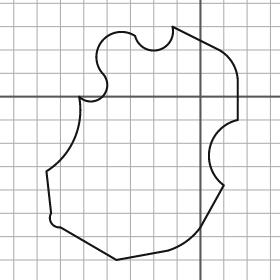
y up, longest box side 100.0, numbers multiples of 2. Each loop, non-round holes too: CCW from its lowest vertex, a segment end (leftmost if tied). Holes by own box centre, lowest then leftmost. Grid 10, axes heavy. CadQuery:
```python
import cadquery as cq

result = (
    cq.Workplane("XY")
    .moveTo(-36.0, -70.0)
    .lineTo(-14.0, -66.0)
    .threePointArc((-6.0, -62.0), (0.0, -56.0))
    .lineTo(10.0, -38.0)
    .threePointArc((4.0, -22.0), (16.0, -10.0))
    .lineTo(16.0, 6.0)
    .threePointArc((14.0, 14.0), (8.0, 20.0))
    .lineTo(-12.0, 30.0)
    .threePointArc((-18.0, 20.0), (-28.0, 26.0))
    .threePointArc((-42.0, 24.0), (-42.0, 10.0))
    .threePointArc((-42.0, 0.0), (-52.0, 0.0))
    .threePointArc((-54.0, -18.0), (-66.0, -32.0))
    .lineTo(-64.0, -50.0)
    .threePointArc((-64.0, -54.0), (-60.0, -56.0))
    .close()
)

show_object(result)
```